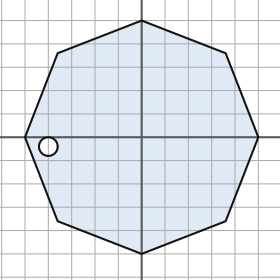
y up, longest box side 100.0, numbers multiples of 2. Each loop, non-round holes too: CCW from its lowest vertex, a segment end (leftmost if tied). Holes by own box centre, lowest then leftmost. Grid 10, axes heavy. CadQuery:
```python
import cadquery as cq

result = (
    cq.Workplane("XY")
    .moveTo(0.0, -50.0)
    .lineTo(36.0, -36.0)
    .lineTo(50.0, 0.0)
    .lineTo(36.0, 36.0)
    .lineTo(0.0, 50.0)
    .lineTo(-36.0, 36.0)
    .lineTo(-50.0, 0.0)
    .lineTo(-36.0, -36.0)
    .close()
    .moveTo(-40.0, -4.0)
    .circle(4.0)
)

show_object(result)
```